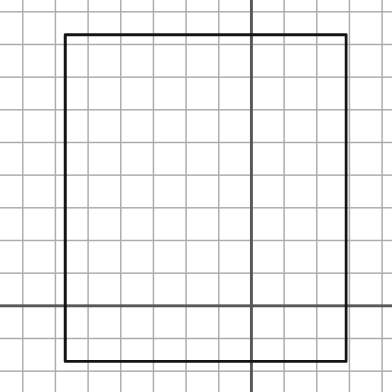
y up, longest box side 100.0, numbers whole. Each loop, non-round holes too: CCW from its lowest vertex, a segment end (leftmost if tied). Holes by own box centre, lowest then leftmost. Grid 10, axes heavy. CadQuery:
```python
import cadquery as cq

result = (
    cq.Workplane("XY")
    .moveTo(-57.0, -17.0)
    .lineTo(29.0, -17.0)
    .lineTo(29.0, 83.0)
    .lineTo(-57.0, 83.0)
    .close()
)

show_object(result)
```